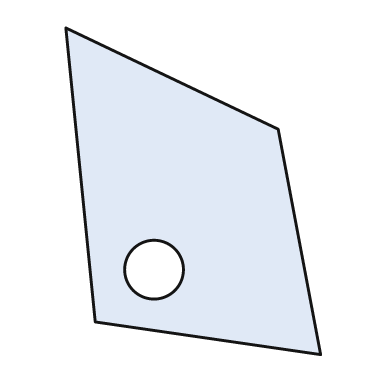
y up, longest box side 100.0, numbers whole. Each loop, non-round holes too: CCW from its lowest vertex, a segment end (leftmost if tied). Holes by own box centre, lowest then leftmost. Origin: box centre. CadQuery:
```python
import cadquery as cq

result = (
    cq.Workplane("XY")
    .moveTo(39.0, -50.0)
    .lineTo(26.0, 19.0)
    .lineTo(-39.0, 50.0)
    .lineTo(-30.0, -40.0)
    .close()
    .moveTo(-12.0, -24.0)
    .circle(9.0)
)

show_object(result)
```